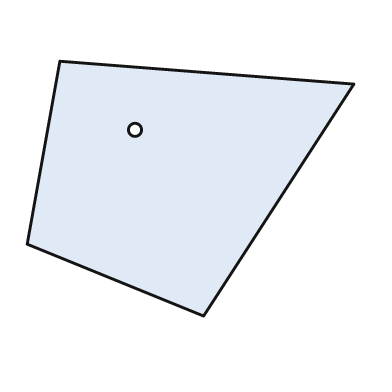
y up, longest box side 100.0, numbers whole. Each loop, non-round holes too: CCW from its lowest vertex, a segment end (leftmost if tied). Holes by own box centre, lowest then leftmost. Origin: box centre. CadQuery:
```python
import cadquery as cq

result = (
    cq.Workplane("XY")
    .moveTo(4.0, -39.0)
    .lineTo(50.0, 32.0)
    .lineTo(-40.0, 39.0)
    .lineTo(-50.0, -17.0)
    .close()
    .moveTo(-17.0, 18.0)
    .circle(2.0)
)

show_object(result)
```